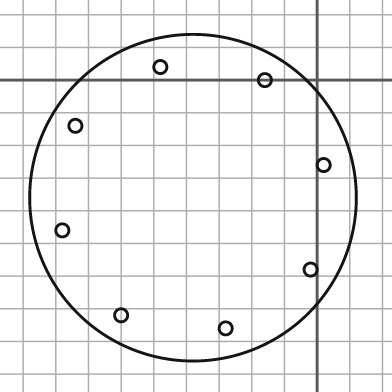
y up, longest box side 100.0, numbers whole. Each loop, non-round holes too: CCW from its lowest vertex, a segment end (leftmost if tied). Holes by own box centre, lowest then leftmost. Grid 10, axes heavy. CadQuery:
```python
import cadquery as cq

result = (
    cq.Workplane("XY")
    .moveTo(-38.0, -36.0)
    .circle(50.0)
    .moveTo(-28.0, -76.0)
    .circle(2.0)
    .moveTo(-60.0, -72.0)
    .circle(2.0)
    .moveTo(-2.0, -58.0)
    .circle(2.0)
    .moveTo(-78.0, -46.0)
    .circle(2.0)
    .moveTo(2.0, -26.0)
    .circle(2.0)
    .moveTo(-74.0, -14.0)
    .circle(2.0)
    .moveTo(-16.0, 0.0)
    .circle(2.0)
    .moveTo(-48.0, 4.0)
    .circle(2.0)
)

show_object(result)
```